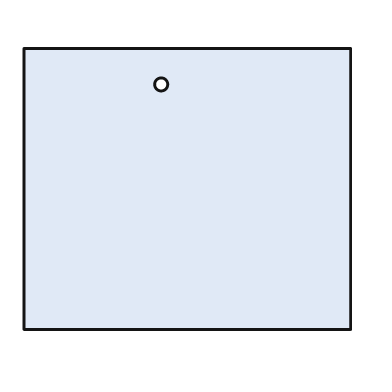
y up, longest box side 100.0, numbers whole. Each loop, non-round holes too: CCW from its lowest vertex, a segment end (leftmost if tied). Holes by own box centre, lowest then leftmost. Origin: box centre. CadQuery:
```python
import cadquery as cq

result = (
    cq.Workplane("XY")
    .moveTo(-50.0, -43.0)
    .lineTo(50.0, -43.0)
    .lineTo(50.0, 43.0)
    .lineTo(-50.0, 43.0)
    .close()
    .moveTo(-8.0, 32.0)
    .circle(2.0)
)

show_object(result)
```